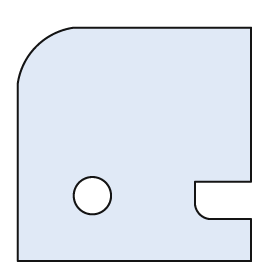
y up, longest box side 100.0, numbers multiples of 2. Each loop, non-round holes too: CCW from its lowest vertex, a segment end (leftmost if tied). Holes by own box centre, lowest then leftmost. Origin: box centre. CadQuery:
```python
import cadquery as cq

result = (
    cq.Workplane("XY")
    .moveTo(-50.0, -50.0)
    .lineTo(50.0, -50.0)
    .lineTo(50.0, -32.0)
    .lineTo(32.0, -32.0)
    .threePointArc((28.0, -30.0), (26.0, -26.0))
    .lineTo(26.0, -16.0)
    .lineTo(50.0, -16.0)
    .lineTo(50.0, 50.0)
    .lineTo(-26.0, 50.0)
    .threePointArc((-42.0, 42.0), (-50.0, 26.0))
    .close()
    .moveTo(-18.0, -22.0)
    .circle(8.0)
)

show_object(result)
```